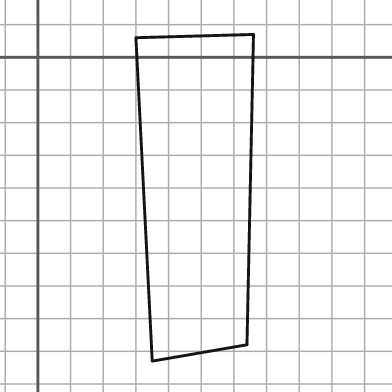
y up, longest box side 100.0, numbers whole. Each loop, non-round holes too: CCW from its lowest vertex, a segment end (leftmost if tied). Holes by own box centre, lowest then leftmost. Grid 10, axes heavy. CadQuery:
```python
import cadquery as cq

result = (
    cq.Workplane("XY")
    .moveTo(35.0, -93.0)
    .lineTo(64.0, -88.0)
    .lineTo(66.0, 7.0)
    .lineTo(30.0, 6.0)
    .close()
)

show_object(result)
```